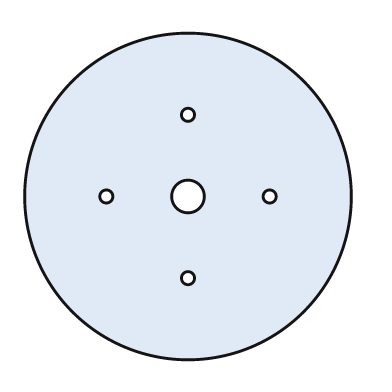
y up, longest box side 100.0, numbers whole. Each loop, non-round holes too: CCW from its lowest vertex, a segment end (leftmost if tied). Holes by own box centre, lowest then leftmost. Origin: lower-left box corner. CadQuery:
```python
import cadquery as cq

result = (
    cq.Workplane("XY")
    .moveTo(50.0, 50.0)
    .circle(50.0)
    .moveTo(50.0, 25.0)
    .circle(2.0)
    .moveTo(25.0, 50.0)
    .circle(2.0)
    .moveTo(50.0, 50.0)
    .circle(5.0)
    .moveTo(75.0, 50.0)
    .circle(2.0)
    .moveTo(50.0, 75.0)
    .circle(2.0)
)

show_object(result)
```